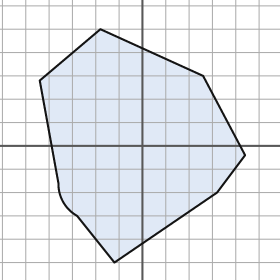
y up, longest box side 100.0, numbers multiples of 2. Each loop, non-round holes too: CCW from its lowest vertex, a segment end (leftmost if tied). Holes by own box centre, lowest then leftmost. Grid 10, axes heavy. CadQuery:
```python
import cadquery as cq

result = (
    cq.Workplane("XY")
    .moveTo(-12.0, -50.0)
    .lineTo(32.0, -20.0)
    .lineTo(44.0, -4.0)
    .lineTo(26.0, 30.0)
    .lineTo(-18.0, 50.0)
    .lineTo(-44.0, 28.0)
    .lineTo(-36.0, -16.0)
    .threePointArc((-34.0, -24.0), (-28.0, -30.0))
    .close()
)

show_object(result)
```